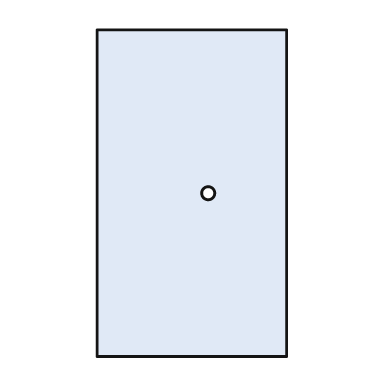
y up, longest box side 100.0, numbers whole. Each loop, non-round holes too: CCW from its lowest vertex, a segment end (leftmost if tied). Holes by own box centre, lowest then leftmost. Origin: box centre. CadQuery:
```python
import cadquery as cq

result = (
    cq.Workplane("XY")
    .moveTo(-29.0, -50.0)
    .lineTo(29.0, -50.0)
    .lineTo(29.0, 50.0)
    .lineTo(-29.0, 50.0)
    .close()
    .moveTo(5.0, 0.0)
    .circle(2.0)
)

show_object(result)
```